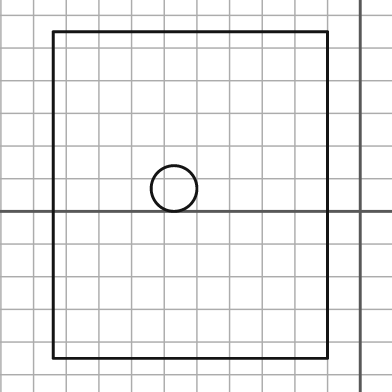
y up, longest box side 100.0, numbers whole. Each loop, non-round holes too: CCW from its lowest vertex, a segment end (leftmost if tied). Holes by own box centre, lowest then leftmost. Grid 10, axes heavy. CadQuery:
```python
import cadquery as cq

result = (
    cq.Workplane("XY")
    .moveTo(-94.0, -45.0)
    .lineTo(-10.0, -45.0)
    .lineTo(-10.0, 55.0)
    .lineTo(-94.0, 55.0)
    .close()
    .moveTo(-57.0, 7.0)
    .circle(7.0)
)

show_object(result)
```